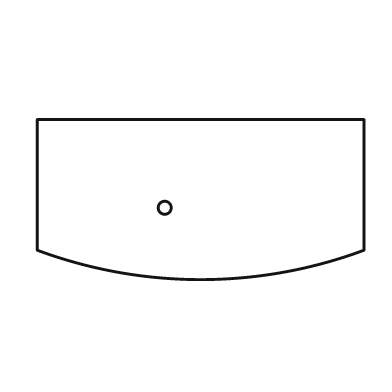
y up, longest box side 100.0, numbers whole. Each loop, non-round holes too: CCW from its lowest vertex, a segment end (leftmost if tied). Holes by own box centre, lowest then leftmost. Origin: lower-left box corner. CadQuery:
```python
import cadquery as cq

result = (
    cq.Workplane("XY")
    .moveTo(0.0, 9.0)
    .threePointArc((50.0, 0.0), (100.0, 9.0))
    .lineTo(100.0, 49.0)
    .lineTo(0.0, 49.0)
    .close()
    .moveTo(39.0, 22.0)
    .circle(2.0)
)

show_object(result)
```